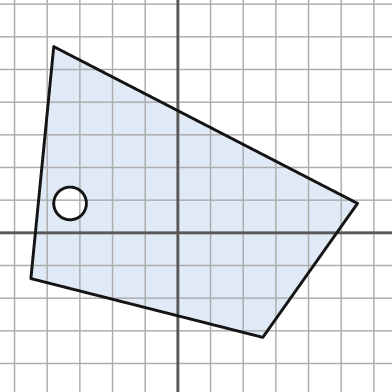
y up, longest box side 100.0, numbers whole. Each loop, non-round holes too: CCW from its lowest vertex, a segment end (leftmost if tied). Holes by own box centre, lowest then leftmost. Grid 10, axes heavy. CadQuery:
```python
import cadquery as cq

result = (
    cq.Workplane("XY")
    .moveTo(26.0, -32.0)
    .lineTo(55.0, 9.0)
    .lineTo(-38.0, 57.0)
    .lineTo(-45.0, -14.0)
    .close()
    .moveTo(-33.0, 9.0)
    .circle(5.0)
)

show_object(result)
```